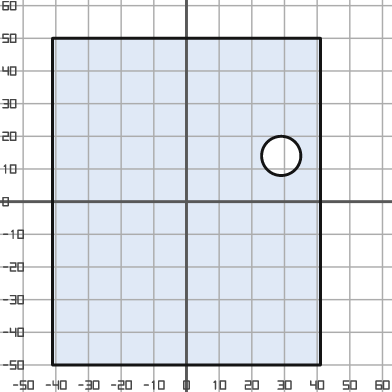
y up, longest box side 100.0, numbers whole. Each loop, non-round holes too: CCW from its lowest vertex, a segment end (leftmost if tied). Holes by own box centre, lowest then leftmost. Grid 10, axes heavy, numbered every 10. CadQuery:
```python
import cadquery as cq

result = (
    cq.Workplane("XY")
    .moveTo(-41.0, -50.0)
    .lineTo(41.0, -50.0)
    .lineTo(41.0, 50.0)
    .lineTo(-41.0, 50.0)
    .close()
    .moveTo(29.0, 14.0)
    .circle(6.0)
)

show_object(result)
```